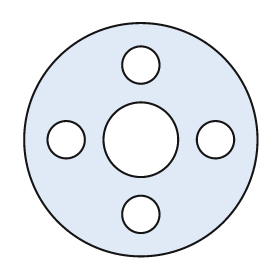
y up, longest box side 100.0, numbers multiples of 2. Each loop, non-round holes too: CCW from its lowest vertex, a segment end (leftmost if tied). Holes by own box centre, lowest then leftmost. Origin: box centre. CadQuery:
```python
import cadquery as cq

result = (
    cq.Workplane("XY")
    .moveTo(0.0, 0.0)
    .circle(50.0)
    .moveTo(0.0, -32.0)
    .circle(8.0)
    .moveTo(-32.0, 0.0)
    .circle(8.0)
    .moveTo(0.0, 0.0)
    .circle(16.0)
    .moveTo(32.0, 0.0)
    .circle(8.0)
    .moveTo(0.0, 32.0)
    .circle(8.0)
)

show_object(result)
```